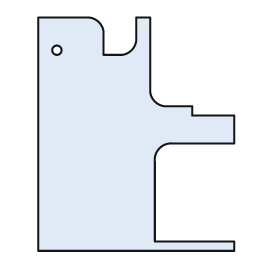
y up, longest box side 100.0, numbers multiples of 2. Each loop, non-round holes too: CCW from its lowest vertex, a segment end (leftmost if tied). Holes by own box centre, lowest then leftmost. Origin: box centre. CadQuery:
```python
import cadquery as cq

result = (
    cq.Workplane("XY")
    .moveTo(-42.0, -50.0)
    .lineTo(42.0, -50.0)
    .lineTo(42.0, -46.0)
    .lineTo(8.0, -46.0)
    .lineTo(8.0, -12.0)
    .threePointArc((10.0, -6.0), (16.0, -4.0))
    .lineTo(42.0, -4.0)
    .lineTo(42.0, 8.0)
    .lineTo(24.0, 8.0)
    .lineTo(24.0, 12.0)
    .lineTo(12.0, 12.0)
    .threePointArc((8.0, 14.0), (6.0, 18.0))
    .lineTo(6.0, 50.0)
    .lineTo(0.0, 50.0)
    .lineTo(0.0, 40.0)
    .threePointArc((-2.0, 36.0), (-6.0, 34.0))
    .lineTo(-14.0, 34.0)
    .lineTo(-14.0, 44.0)
    .threePointArc((-16.0, 48.0), (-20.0, 50.0))
    .lineTo(-42.0, 50.0)
    .close()
    .moveTo(-34.0, 36.0)
    .circle(2.0)
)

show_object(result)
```